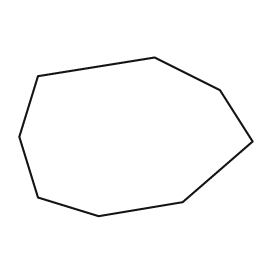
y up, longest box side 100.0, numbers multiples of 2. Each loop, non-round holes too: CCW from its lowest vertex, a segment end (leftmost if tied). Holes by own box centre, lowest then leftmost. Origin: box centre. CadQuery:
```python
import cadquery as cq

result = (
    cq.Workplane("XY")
    .moveTo(-16.0, -34.0)
    .lineTo(20.0, -28.0)
    .lineTo(50.0, -2.0)
    .lineTo(36.0, 20.0)
    .lineTo(8.0, 34.0)
    .lineTo(-42.0, 26.0)
    .lineTo(-50.0, 0.0)
    .lineTo(-42.0, -26.0)
    .close()
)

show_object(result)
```